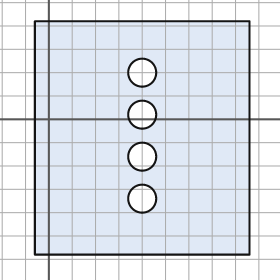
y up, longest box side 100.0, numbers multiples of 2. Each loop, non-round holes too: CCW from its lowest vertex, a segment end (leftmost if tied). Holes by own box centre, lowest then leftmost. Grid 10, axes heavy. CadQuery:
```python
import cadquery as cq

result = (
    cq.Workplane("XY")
    .moveTo(-6.0, -58.0)
    .lineTo(86.0, -58.0)
    .lineTo(86.0, 42.0)
    .lineTo(-6.0, 42.0)
    .close()
    .moveTo(40.0, -34.0)
    .circle(6.0)
    .moveTo(40.0, -16.0)
    .circle(6.0)
    .moveTo(40.0, 2.0)
    .circle(6.0)
    .moveTo(40.0, 20.0)
    .circle(6.0)
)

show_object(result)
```